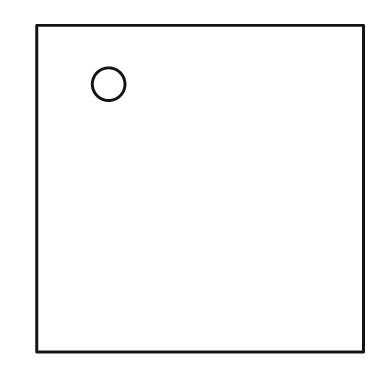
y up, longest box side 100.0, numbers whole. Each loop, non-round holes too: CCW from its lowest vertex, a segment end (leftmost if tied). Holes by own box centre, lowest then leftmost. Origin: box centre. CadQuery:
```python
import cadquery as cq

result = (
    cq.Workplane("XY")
    .moveTo(-50.0, -50.0)
    .lineTo(50.0, -50.0)
    .lineTo(50.0, 50.0)
    .lineTo(-50.0, 50.0)
    .close()
    .moveTo(-28.0, 32.0)
    .circle(5.0)
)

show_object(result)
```